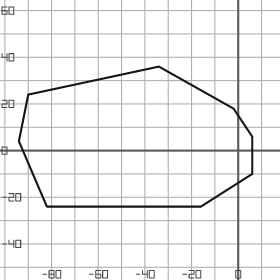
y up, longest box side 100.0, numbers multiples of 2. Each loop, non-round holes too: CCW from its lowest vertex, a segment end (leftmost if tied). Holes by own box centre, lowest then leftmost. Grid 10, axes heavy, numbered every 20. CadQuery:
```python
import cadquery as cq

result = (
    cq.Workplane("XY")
    .moveTo(-82.0, -24.0)
    .lineTo(-16.0, -24.0)
    .lineTo(6.0, -10.0)
    .lineTo(6.0, 6.0)
    .lineTo(-2.0, 18.0)
    .lineTo(-34.0, 36.0)
    .lineTo(-90.0, 24.0)
    .lineTo(-94.0, 4.0)
    .close()
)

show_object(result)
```